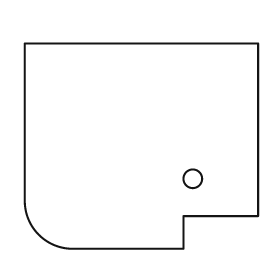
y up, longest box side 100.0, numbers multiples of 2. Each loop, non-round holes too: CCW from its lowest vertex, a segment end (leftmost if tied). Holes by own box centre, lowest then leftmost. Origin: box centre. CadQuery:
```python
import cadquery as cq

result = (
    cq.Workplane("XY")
    .moveTo(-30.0, -44.0)
    .lineTo(18.0, -44.0)
    .lineTo(18.0, -30.0)
    .lineTo(50.0, -30.0)
    .lineTo(50.0, 44.0)
    .lineTo(-50.0, 44.0)
    .lineTo(-50.0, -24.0)
    .threePointArc((-44.0, -38.0), (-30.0, -44.0))
    .close()
    .moveTo(22.0, -14.0)
    .circle(4.0)
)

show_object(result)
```